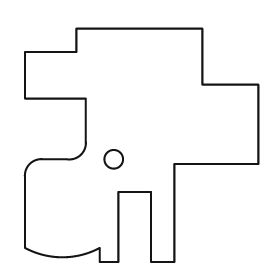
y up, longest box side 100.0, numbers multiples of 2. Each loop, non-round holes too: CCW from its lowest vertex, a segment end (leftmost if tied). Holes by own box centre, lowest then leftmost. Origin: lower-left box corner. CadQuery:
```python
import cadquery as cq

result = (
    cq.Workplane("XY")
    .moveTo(32.0, 0.0)
    .lineTo(40.0, 0.0)
    .lineTo(40.0, 30.0)
    .lineTo(54.0, 30.0)
    .lineTo(54.0, 0.0)
    .lineTo(64.0, 0.0)
    .lineTo(64.0, 42.0)
    .lineTo(100.0, 42.0)
    .lineTo(100.0, 76.0)
    .lineTo(76.0, 76.0)
    .lineTo(76.0, 100.0)
    .lineTo(22.0, 100.0)
    .lineTo(22.0, 90.0)
    .lineTo(0.0, 90.0)
    .lineTo(0.0, 70.0)
    .lineTo(26.0, 70.0)
    .lineTo(26.0, 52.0)
    .threePointArc((24.0, 46.0), (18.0, 44.0))
    .lineTo(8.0, 44.0)
    .threePointArc((2.0, 42.0), (0.0, 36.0))
    .lineTo(0.0, 6.0)
    .threePointArc((16.0, 2.0), (32.0, 6.0))
    .close()
    .moveTo(38.0, 44.0)
    .circle(4.0)
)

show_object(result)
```